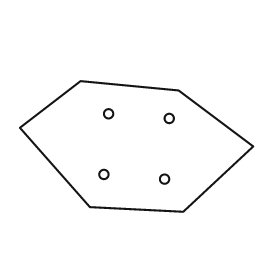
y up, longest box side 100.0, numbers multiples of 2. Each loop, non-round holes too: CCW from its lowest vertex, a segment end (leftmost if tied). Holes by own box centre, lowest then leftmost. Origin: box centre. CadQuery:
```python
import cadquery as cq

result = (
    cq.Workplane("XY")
    .moveTo(20.0, -28.0)
    .lineTo(50.0, 0.0)
    .lineTo(18.0, 24.0)
    .lineTo(-24.0, 28.0)
    .lineTo(-50.0, 8.0)
    .lineTo(-20.0, -26.0)
    .close()
    .moveTo(12.0, -14.0)
    .circle(2.0)
    .moveTo(-14.0, -12.0)
    .circle(2.0)
    .moveTo(14.0, 12.0)
    .circle(2.0)
    .moveTo(-12.0, 14.0)
    .circle(2.0)
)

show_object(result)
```